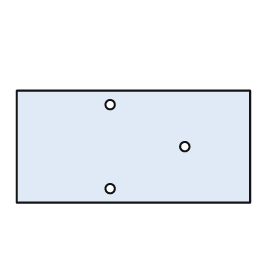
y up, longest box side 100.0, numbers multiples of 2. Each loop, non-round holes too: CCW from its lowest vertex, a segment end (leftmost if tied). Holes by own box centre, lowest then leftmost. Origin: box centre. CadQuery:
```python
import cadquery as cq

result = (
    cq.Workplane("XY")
    .moveTo(-50.0, -24.0)
    .lineTo(50.0, -24.0)
    .lineTo(50.0, 24.0)
    .lineTo(-50.0, 24.0)
    .close()
    .moveTo(-10.0, -18.0)
    .circle(2.0)
    .moveTo(22.0, 0.0)
    .circle(2.0)
    .moveTo(-10.0, 18.0)
    .circle(2.0)
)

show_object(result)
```